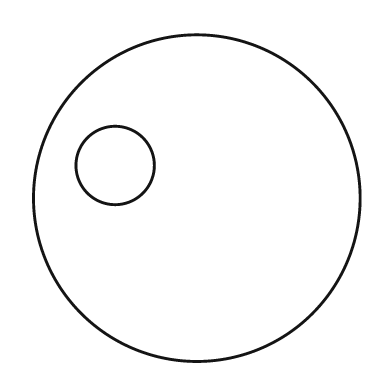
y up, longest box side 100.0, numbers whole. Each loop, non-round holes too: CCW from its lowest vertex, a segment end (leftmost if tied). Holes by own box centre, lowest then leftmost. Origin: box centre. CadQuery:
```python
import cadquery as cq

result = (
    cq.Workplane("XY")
    .moveTo(0.0, 0.0)
    .circle(50.0)
    .moveTo(-25.0, 10.0)
    .circle(12.0)
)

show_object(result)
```